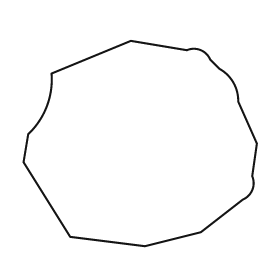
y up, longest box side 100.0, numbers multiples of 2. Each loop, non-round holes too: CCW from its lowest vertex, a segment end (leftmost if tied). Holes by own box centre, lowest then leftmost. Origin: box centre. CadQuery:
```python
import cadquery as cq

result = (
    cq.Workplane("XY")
    .moveTo(2.0, -44.0)
    .lineTo(26.0, -38.0)
    .lineTo(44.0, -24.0)
    .threePointArc((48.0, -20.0), (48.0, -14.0))
    .lineTo(50.0, 0.0)
    .lineTo(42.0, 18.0)
    .threePointArc((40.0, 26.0), (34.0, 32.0))
    .lineTo(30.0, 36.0)
    .threePointArc((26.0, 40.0), (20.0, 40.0))
    .lineTo(-4.0, 44.0)
    .lineTo(-38.0, 30.0)
    .threePointArc((-40.0, 16.0), (-48.0, 4.0))
    .lineTo(-50.0, -8.0)
    .lineTo(-30.0, -40.0)
    .close()
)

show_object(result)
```